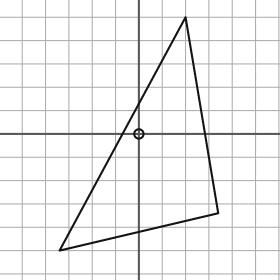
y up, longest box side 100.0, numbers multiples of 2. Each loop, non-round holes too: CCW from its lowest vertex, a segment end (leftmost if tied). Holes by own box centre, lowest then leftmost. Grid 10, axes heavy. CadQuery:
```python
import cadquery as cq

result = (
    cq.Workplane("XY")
    .moveTo(-34.0, -50.0)
    .lineTo(34.0, -34.0)
    .lineTo(20.0, 50.0)
    .close()
    .moveTo(0.0, 0.0)
    .circle(2.0)
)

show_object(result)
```